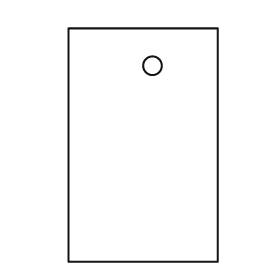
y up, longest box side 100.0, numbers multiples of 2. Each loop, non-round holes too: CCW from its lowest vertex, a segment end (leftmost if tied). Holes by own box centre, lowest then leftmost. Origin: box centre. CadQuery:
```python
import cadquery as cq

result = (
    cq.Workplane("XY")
    .moveTo(-32.0, -50.0)
    .lineTo(32.0, -50.0)
    .lineTo(32.0, 50.0)
    .lineTo(-32.0, 50.0)
    .close()
    .moveTo(4.0, 34.0)
    .circle(4.0)
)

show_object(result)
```